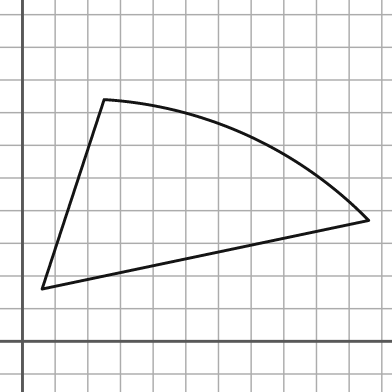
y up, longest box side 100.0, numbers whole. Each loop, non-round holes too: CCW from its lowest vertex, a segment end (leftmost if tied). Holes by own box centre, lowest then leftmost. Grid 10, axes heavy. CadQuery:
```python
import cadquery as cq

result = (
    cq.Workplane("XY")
    .moveTo(6.0, 16.0)
    .lineTo(106.0, 37.0)
    .threePointArc((69.0, 63.0), (25.0, 74.0))
    .close()
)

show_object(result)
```